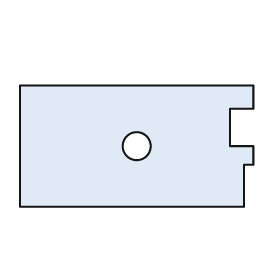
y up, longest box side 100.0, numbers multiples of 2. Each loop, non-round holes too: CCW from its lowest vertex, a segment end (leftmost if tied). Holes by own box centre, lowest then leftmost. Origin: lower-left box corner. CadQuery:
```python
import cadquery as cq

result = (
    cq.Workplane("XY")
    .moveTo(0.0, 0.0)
    .lineTo(96.0, 0.0)
    .lineTo(96.0, 18.0)
    .lineTo(100.0, 18.0)
    .lineTo(100.0, 26.0)
    .lineTo(90.0, 26.0)
    .lineTo(90.0, 42.0)
    .lineTo(100.0, 42.0)
    .lineTo(100.0, 52.0)
    .lineTo(0.0, 52.0)
    .close()
    .moveTo(50.0, 26.0)
    .circle(6.0)
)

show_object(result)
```